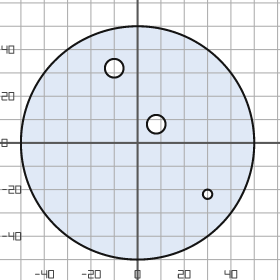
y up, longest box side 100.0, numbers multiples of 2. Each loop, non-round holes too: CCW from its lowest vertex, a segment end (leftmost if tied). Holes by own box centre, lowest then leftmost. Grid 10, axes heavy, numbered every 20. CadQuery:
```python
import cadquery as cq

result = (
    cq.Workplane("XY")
    .moveTo(0.0, 0.0)
    .circle(50.0)
    .moveTo(30.0, -22.0)
    .circle(2.0)
    .moveTo(8.0, 8.0)
    .circle(4.0)
    .moveTo(-10.0, 32.0)
    .circle(4.0)
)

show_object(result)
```